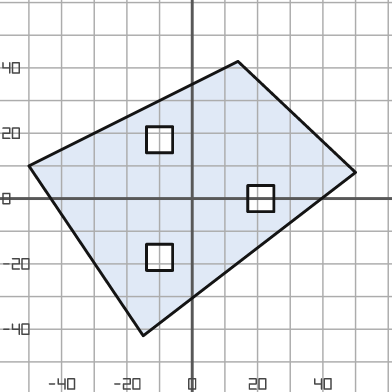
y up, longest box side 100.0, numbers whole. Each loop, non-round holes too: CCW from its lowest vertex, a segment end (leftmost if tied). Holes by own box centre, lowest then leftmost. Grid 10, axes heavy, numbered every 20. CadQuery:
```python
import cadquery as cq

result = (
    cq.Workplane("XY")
    .moveTo(-15.0, -42.0)
    .lineTo(50.0, 8.0)
    .lineTo(14.0, 42.0)
    .lineTo(-50.0, 10.0)
    .close()
    .moveTo(-14.0, -22.0)
    .lineTo(-6.0, -22.0)
    .lineTo(-6.0, -14.0)
    .lineTo(-14.0, -14.0)
    .close()
    .moveTo(17.0, -4.0)
    .lineTo(25.0, -4.0)
    .lineTo(25.0, 4.0)
    .lineTo(17.0, 4.0)
    .close()
    .moveTo(-14.0, 14.0)
    .lineTo(-6.0, 14.0)
    .lineTo(-6.0, 22.0)
    .lineTo(-14.0, 22.0)
    .close()
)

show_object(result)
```